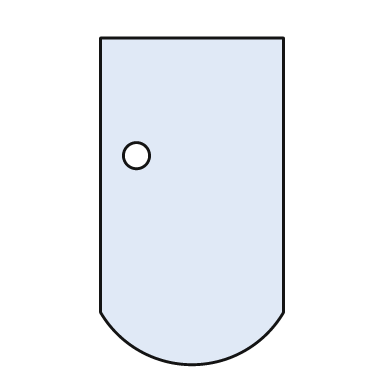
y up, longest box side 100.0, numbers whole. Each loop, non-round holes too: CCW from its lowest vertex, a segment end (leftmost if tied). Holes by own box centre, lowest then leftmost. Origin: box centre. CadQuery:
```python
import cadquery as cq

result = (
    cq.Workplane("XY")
    .moveTo(-28.0, -34.0)
    .threePointArc((0.0, -50.0), (28.0, -34.0))
    .lineTo(28.0, 50.0)
    .lineTo(-28.0, 50.0)
    .close()
    .moveTo(-17.0, 14.0)
    .circle(4.0)
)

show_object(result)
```